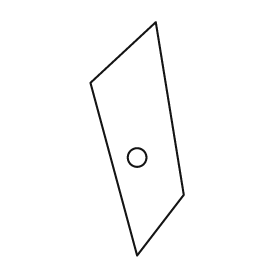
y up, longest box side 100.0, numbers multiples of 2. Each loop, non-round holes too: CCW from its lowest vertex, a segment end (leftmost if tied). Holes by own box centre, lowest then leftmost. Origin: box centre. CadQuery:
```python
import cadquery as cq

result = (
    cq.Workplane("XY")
    .moveTo(0.0, -50.0)
    .lineTo(20.0, -24.0)
    .lineTo(8.0, 50.0)
    .lineTo(-20.0, 24.0)
    .close()
    .moveTo(0.0, -8.0)
    .circle(4.0)
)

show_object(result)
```